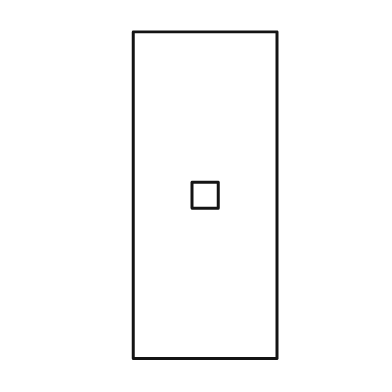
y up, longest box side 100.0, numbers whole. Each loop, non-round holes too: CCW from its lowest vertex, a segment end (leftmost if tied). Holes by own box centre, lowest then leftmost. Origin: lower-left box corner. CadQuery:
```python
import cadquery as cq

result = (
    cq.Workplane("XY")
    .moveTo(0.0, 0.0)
    .lineTo(44.0, 0.0)
    .lineTo(44.0, 100.0)
    .lineTo(0.0, 100.0)
    .close()
    .moveTo(18.0, 46.0)
    .lineTo(26.0, 46.0)
    .lineTo(26.0, 54.0)
    .lineTo(18.0, 54.0)
    .close()
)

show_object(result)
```